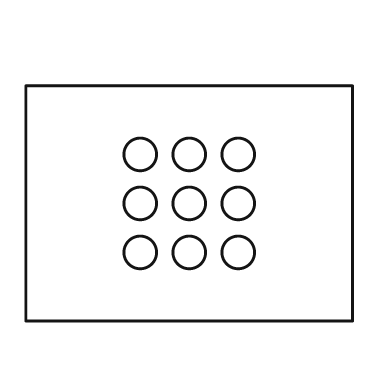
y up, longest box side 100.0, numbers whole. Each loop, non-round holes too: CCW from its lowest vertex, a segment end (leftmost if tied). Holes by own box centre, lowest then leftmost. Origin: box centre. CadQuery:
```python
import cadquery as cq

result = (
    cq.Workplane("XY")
    .moveTo(-50.0, -36.0)
    .lineTo(50.0, -36.0)
    .lineTo(50.0, 36.0)
    .lineTo(-50.0, 36.0)
    .close()
    .moveTo(-15.0, -15.0)
    .circle(5.0)
    .moveTo(0.0, -15.0)
    .circle(5.0)
    .moveTo(15.0, -15.0)
    .circle(5.0)
    .moveTo(-15.0, 0.0)
    .circle(5.0)
    .moveTo(0.0, 0.0)
    .circle(5.0)
    .moveTo(15.0, 0.0)
    .circle(5.0)
    .moveTo(-15.0, 15.0)
    .circle(5.0)
    .moveTo(0.0, 15.0)
    .circle(5.0)
    .moveTo(15.0, 15.0)
    .circle(5.0)
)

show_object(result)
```